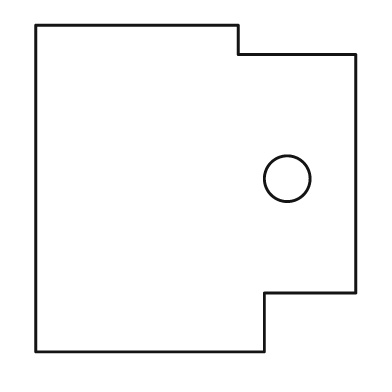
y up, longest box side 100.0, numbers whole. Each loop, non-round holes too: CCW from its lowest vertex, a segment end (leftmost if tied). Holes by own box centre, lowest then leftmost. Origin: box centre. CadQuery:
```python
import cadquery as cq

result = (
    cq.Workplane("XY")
    .moveTo(-49.0, -50.0)
    .lineTo(21.0, -50.0)
    .lineTo(21.0, -32.0)
    .lineTo(49.0, -32.0)
    .lineTo(49.0, 41.0)
    .lineTo(13.0, 41.0)
    .lineTo(13.0, 50.0)
    .lineTo(-49.0, 50.0)
    .close()
    .moveTo(28.0, 3.0)
    .circle(7.0)
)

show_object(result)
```